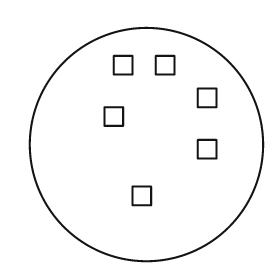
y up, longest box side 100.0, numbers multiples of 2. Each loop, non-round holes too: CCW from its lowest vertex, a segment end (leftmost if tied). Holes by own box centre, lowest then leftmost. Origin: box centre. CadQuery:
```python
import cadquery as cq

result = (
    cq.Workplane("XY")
    .moveTo(0.0, 0.0)
    .circle(50.0)
    .moveTo(-6.0, -26.0)
    .lineTo(2.0, -26.0)
    .lineTo(2.0, -18.0)
    .lineTo(-6.0, -18.0)
    .close()
    .moveTo(22.0, -6.0)
    .lineTo(30.0, -6.0)
    .lineTo(30.0, 2.0)
    .lineTo(22.0, 2.0)
    .close()
    .moveTo(-18.0, 8.0)
    .lineTo(-10.0, 8.0)
    .lineTo(-10.0, 16.0)
    .lineTo(-18.0, 16.0)
    .close()
    .moveTo(22.0, 16.0)
    .lineTo(30.0, 16.0)
    .lineTo(30.0, 24.0)
    .lineTo(22.0, 24.0)
    .close()
    .moveTo(-14.0, 30.0)
    .lineTo(-6.0, 30.0)
    .lineTo(-6.0, 38.0)
    .lineTo(-14.0, 38.0)
    .close()
    .moveTo(4.0, 30.0)
    .lineTo(12.0, 30.0)
    .lineTo(12.0, 38.0)
    .lineTo(4.0, 38.0)
    .close()
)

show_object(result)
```